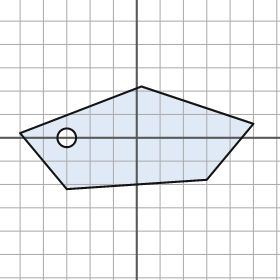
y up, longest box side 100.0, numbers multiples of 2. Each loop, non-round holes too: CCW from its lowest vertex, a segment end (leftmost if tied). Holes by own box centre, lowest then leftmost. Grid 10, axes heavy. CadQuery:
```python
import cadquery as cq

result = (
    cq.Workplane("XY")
    .moveTo(-30.0, -22.0)
    .lineTo(30.0, -18.0)
    .lineTo(50.0, 6.0)
    .lineTo(2.0, 22.0)
    .lineTo(-50.0, 2.0)
    .close()
    .moveTo(-30.0, 0.0)
    .circle(4.0)
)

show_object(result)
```